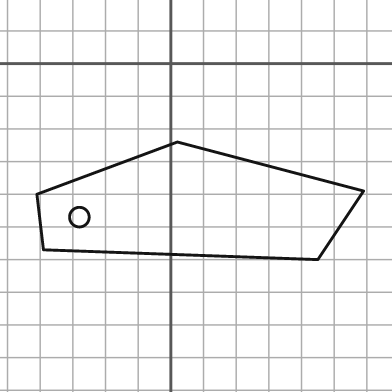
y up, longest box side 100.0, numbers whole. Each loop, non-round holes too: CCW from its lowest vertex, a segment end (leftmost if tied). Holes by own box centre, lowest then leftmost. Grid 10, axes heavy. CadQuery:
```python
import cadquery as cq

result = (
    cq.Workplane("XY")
    .moveTo(45.0, -60.0)
    .lineTo(59.0, -39.0)
    .lineTo(2.0, -24.0)
    .lineTo(-41.0, -40.0)
    .lineTo(-39.0, -57.0)
    .close()
    .moveTo(-28.0, -47.0)
    .circle(3.0)
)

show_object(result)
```